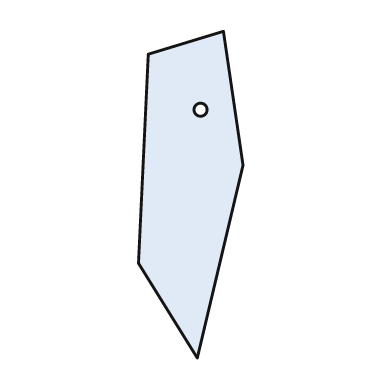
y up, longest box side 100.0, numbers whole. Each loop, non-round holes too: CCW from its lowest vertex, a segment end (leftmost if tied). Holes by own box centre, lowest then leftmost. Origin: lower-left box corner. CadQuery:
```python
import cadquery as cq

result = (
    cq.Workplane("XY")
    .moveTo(18.0, 0.0)
    .lineTo(32.0, 59.0)
    .lineTo(26.0, 100.0)
    .lineTo(3.0, 93.0)
    .lineTo(0.0, 29.0)
    .close()
    .moveTo(19.0, 76.0)
    .circle(2.0)
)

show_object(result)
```